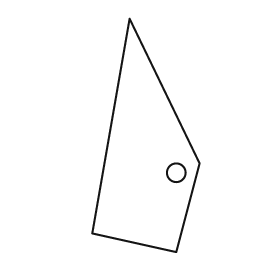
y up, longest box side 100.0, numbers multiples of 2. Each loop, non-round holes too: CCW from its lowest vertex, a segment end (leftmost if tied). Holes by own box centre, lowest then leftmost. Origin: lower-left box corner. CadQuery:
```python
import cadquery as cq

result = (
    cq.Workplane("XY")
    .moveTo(36.0, 0.0)
    .lineTo(46.0, 38.0)
    .lineTo(16.0, 100.0)
    .lineTo(0.0, 8.0)
    .close()
    .moveTo(36.0, 34.0)
    .circle(4.0)
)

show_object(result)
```